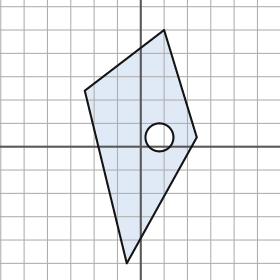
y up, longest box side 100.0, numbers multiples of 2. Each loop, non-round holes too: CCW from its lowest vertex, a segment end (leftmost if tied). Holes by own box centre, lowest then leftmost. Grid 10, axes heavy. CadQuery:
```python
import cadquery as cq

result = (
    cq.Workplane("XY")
    .moveTo(-6.0, -50.0)
    .lineTo(24.0, 4.0)
    .lineTo(10.0, 50.0)
    .lineTo(-24.0, 24.0)
    .close()
    .moveTo(8.0, 4.0)
    .circle(6.0)
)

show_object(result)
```